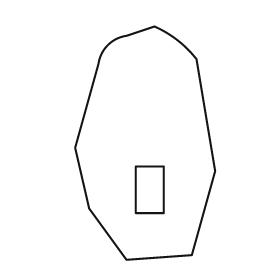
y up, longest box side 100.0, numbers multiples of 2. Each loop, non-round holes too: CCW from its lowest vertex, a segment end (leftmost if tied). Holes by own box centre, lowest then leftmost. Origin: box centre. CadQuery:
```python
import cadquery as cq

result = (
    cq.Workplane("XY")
    .moveTo(-8.0, -50.0)
    .lineTo(20.0, -48.0)
    .lineTo(30.0, -12.0)
    .lineTo(22.0, 36.0)
    .threePointArc((14.0, 44.0), (4.0, 50.0))
    .lineTo(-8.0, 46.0)
    .threePointArc((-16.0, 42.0), (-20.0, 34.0))
    .lineTo(-30.0, -2.0)
    .lineTo(-24.0, -28.0)
    .close()
    .moveTo(-4.0, -30.0)
    .lineTo(8.0, -30.0)
    .lineTo(8.0, -10.0)
    .lineTo(-4.0, -10.0)
    .close()
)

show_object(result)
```